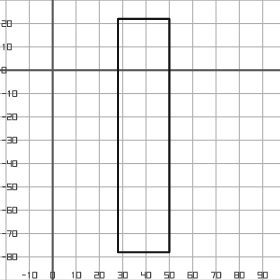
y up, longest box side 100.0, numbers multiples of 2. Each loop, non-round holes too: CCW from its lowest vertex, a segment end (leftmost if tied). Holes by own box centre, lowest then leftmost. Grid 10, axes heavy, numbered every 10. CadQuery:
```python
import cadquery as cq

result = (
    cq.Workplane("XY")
    .moveTo(28.0, -78.0)
    .lineTo(50.0, -78.0)
    .lineTo(50.0, 22.0)
    .lineTo(28.0, 22.0)
    .close()
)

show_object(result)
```